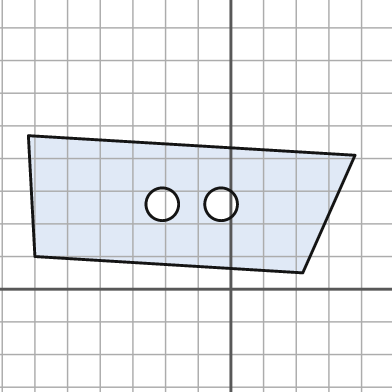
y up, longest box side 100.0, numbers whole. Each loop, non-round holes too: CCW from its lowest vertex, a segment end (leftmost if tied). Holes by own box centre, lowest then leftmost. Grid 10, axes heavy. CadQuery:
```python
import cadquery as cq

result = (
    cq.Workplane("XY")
    .moveTo(22.0, 5.0)
    .lineTo(38.0, 41.0)
    .lineTo(-62.0, 47.0)
    .lineTo(-60.0, 10.0)
    .close()
    .moveTo(-21.0, 26.0)
    .circle(5.0)
    .moveTo(-3.0, 26.0)
    .circle(5.0)
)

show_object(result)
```